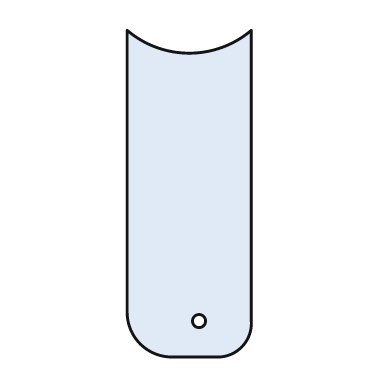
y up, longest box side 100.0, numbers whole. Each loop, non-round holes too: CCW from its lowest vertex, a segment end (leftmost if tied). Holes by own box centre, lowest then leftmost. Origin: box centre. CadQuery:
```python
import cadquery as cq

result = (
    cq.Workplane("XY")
    .moveTo(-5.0, -50.0)
    .lineTo(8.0, -50.0)
    .threePointArc((16.0, -47.0), (19.0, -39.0))
    .lineTo(19.0, 50.0)
    .threePointArc((0.0, 43.0), (-19.0, 50.0))
    .lineTo(-19.0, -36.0)
    .threePointArc((-15.0, -46.0), (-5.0, -50.0))
    .close()
    .moveTo(3.0, -39.0)
    .circle(2.0)
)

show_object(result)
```